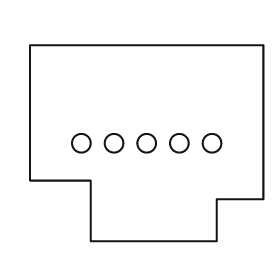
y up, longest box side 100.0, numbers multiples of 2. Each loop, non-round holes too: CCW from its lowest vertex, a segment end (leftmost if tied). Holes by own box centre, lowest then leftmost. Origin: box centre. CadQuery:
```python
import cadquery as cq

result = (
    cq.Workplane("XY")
    .moveTo(-24.0, -42.0)
    .lineTo(30.0, -42.0)
    .lineTo(30.0, -24.0)
    .lineTo(50.0, -24.0)
    .lineTo(50.0, 42.0)
    .lineTo(-50.0, 42.0)
    .lineTo(-50.0, -16.0)
    .lineTo(-24.0, -16.0)
    .close()
    .moveTo(-28.0, 0.0)
    .circle(4.0)
    .moveTo(-14.0, 0.0)
    .circle(4.0)
    .moveTo(0.0, 0.0)
    .circle(4.0)
    .moveTo(14.0, 0.0)
    .circle(4.0)
    .moveTo(28.0, 0.0)
    .circle(4.0)
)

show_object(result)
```